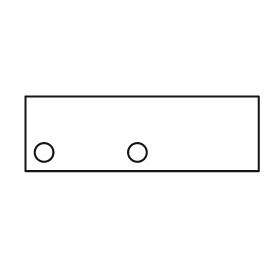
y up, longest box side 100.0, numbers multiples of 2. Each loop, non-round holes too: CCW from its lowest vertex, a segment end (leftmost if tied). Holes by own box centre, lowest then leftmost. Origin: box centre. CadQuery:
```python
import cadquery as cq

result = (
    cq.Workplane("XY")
    .moveTo(-50.0, -16.0)
    .lineTo(50.0, -16.0)
    .lineTo(50.0, 16.0)
    .lineTo(-50.0, 16.0)
    .close()
    .moveTo(-42.0, -8.0)
    .circle(4.0)
    .moveTo(-2.0, -8.0)
    .circle(4.0)
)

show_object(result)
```